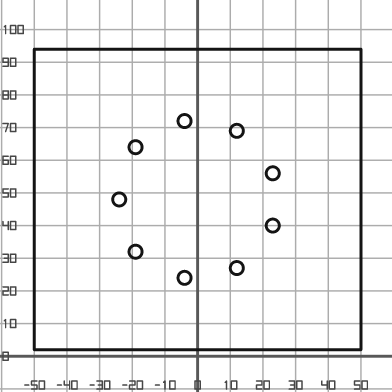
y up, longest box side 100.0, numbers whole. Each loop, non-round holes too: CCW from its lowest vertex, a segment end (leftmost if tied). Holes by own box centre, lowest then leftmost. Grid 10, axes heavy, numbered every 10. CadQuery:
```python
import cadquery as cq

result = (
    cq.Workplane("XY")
    .moveTo(-50.0, 2.0)
    .lineTo(50.0, 2.0)
    .lineTo(50.0, 94.0)
    .lineTo(-50.0, 94.0)
    .close()
    .moveTo(-4.0, 24.0)
    .circle(2.0)
    .moveTo(12.0, 27.0)
    .circle(2.0)
    .moveTo(-19.0, 32.0)
    .circle(2.0)
    .moveTo(23.0, 40.0)
    .circle(2.0)
    .moveTo(-24.0, 48.0)
    .circle(2.0)
    .moveTo(23.0, 56.0)
    .circle(2.0)
    .moveTo(-19.0, 64.0)
    .circle(2.0)
    .moveTo(12.0, 69.0)
    .circle(2.0)
    .moveTo(-4.0, 72.0)
    .circle(2.0)
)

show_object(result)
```